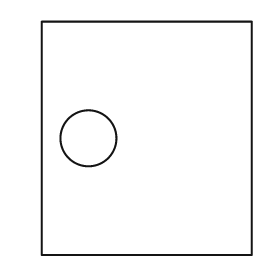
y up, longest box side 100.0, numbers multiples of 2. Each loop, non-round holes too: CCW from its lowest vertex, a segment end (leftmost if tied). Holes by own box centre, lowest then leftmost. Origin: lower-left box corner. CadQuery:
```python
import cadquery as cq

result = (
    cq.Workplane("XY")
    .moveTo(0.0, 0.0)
    .lineTo(90.0, 0.0)
    .lineTo(90.0, 100.0)
    .lineTo(0.0, 100.0)
    .close()
    .moveTo(20.0, 50.0)
    .circle(12.0)
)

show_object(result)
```